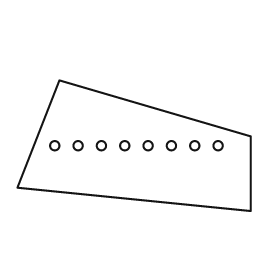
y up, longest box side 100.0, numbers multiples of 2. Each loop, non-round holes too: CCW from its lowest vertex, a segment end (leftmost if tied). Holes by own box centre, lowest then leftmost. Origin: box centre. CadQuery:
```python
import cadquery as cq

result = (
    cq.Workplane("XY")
    .moveTo(50.0, -28.0)
    .lineTo(50.0, 4.0)
    .lineTo(-32.0, 28.0)
    .lineTo(-50.0, -18.0)
    .close()
    .moveTo(-34.0, 0.0)
    .circle(2.0)
    .moveTo(-24.0, 0.0)
    .circle(2.0)
    .moveTo(-14.0, 0.0)
    .circle(2.0)
    .moveTo(-4.0, 0.0)
    .circle(2.0)
    .moveTo(6.0, 0.0)
    .circle(2.0)
    .moveTo(16.0, 0.0)
    .circle(2.0)
    .moveTo(26.0, 0.0)
    .circle(2.0)
    .moveTo(36.0, 0.0)
    .circle(2.0)
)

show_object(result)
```